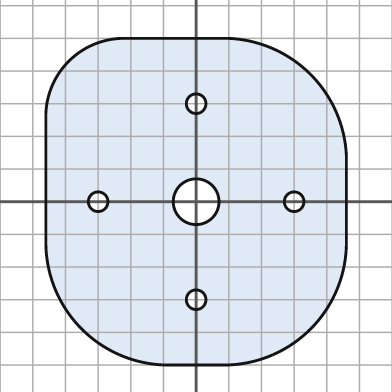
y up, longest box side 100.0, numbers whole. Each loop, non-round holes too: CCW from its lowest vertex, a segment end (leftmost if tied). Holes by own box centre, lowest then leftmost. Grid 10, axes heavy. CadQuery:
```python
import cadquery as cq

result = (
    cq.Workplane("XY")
    .moveTo(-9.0, -50.0)
    .lineTo(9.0, -50.0)
    .threePointArc((35.0, -39.0), (46.0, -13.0))
    .lineTo(46.0, 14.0)
    .threePointArc((35.0, 39.0), (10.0, 50.0))
    .lineTo(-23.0, 50.0)
    .threePointArc((-39.0, 43.0), (-46.0, 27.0))
    .lineTo(-46.0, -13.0)
    .threePointArc((-35.0, -39.0), (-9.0, -50.0))
    .close()
    .moveTo(0.0, -30.0)
    .circle(3.0)
    .moveTo(-30.0, 0.0)
    .circle(3.0)
    .moveTo(0.0, 0.0)
    .circle(7.0)
    .moveTo(30.0, 0.0)
    .circle(3.0)
    .moveTo(0.0, 30.0)
    .circle(3.0)
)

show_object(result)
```